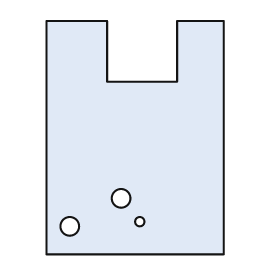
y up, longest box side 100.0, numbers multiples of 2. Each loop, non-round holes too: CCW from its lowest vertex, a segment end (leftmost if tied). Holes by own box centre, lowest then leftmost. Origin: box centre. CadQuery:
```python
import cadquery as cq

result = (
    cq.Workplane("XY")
    .moveTo(-38.0, -50.0)
    .lineTo(38.0, -50.0)
    .lineTo(38.0, 50.0)
    .lineTo(18.0, 50.0)
    .lineTo(18.0, 24.0)
    .lineTo(-12.0, 24.0)
    .lineTo(-12.0, 50.0)
    .lineTo(-38.0, 50.0)
    .close()
    .moveTo(-28.0, -38.0)
    .circle(4.0)
    .moveTo(2.0, -36.0)
    .circle(2.0)
    .moveTo(-6.0, -26.0)
    .circle(4.0)
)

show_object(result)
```